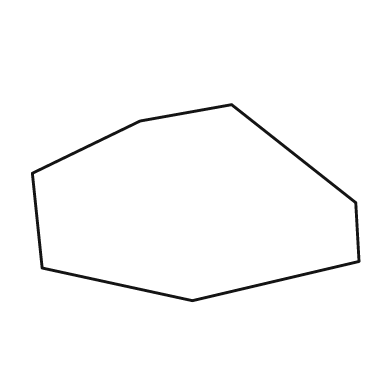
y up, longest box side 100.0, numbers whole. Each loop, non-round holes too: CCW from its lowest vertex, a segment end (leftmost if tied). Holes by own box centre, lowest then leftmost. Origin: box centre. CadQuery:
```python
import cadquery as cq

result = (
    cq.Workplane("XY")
    .moveTo(-1.0, -30.0)
    .lineTo(50.0, -18.0)
    .lineTo(49.0, 0.0)
    .lineTo(11.0, 30.0)
    .lineTo(-17.0, 25.0)
    .lineTo(-50.0, 9.0)
    .lineTo(-47.0, -20.0)
    .close()
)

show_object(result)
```